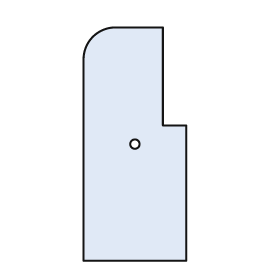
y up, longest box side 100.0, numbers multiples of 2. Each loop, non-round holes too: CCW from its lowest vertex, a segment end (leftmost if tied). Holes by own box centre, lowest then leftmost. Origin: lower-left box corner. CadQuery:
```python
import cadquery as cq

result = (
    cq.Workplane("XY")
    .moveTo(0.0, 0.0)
    .lineTo(44.0, 0.0)
    .lineTo(44.0, 58.0)
    .lineTo(34.0, 58.0)
    .lineTo(34.0, 100.0)
    .lineTo(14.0, 100.0)
    .threePointArc((4.0, 96.0), (0.0, 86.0))
    .close()
    .moveTo(22.0, 50.0)
    .circle(2.0)
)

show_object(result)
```